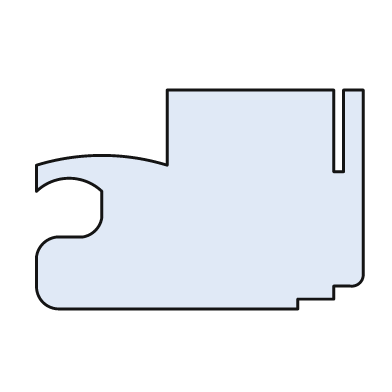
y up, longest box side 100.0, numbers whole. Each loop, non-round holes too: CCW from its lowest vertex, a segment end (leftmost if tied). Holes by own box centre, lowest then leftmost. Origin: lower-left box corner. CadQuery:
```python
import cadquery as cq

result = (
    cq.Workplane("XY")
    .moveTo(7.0, 0.0)
    .lineTo(80.0, 0.0)
    .lineTo(80.0, 3.0)
    .lineTo(91.0, 3.0)
    .lineTo(91.0, 7.0)
    .lineTo(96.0, 7.0)
    .threePointArc((99.0, 8.0), (100.0, 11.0))
    .lineTo(100.0, 67.0)
    .lineTo(94.0, 67.0)
    .lineTo(94.0, 42.0)
    .lineTo(91.0, 42.0)
    .lineTo(91.0, 67.0)
    .lineTo(40.0, 67.0)
    .lineTo(40.0, 44.0)
    .threePointArc((20.0, 47.0), (0.0, 44.0))
    .lineTo(0.0, 36.0)
    .threePointArc((10.0, 40.0), (20.0, 36.0))
    .lineTo(20.0, 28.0)
    .threePointArc((18.0, 24.0), (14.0, 22.0))
    .lineTo(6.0, 22.0)
    .threePointArc((2.0, 20.0), (0.0, 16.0))
    .lineTo(0.0, 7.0)
    .threePointArc((2.0, 2.0), (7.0, 0.0))
    .close()
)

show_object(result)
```